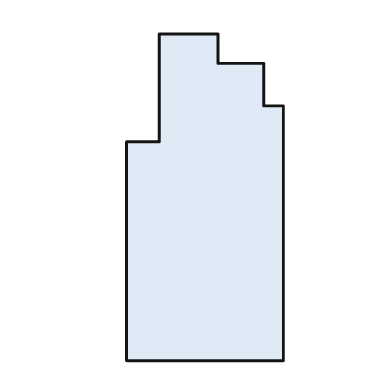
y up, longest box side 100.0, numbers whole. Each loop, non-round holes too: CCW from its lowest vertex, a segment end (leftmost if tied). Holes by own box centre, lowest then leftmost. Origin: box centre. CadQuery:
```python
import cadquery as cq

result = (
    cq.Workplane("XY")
    .moveTo(-24.0, -50.0)
    .lineTo(24.0, -50.0)
    .lineTo(24.0, 28.0)
    .lineTo(18.0, 28.0)
    .lineTo(18.0, 41.0)
    .lineTo(4.0, 41.0)
    .lineTo(4.0, 50.0)
    .lineTo(-14.0, 50.0)
    .lineTo(-14.0, 17.0)
    .lineTo(-24.0, 17.0)
    .close()
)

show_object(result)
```